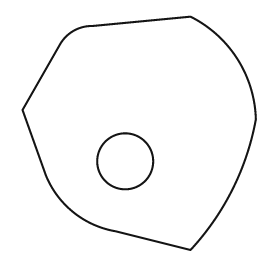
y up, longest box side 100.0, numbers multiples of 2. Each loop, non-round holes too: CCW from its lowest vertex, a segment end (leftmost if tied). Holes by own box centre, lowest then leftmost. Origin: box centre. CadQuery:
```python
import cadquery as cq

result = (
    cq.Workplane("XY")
    .moveTo(22.0, -50.0)
    .threePointArc((40.0, -24.0), (50.0, 6.0))
    .threePointArc((42.0, 32.0), (22.0, 50.0))
    .lineTo(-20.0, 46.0)
    .threePointArc((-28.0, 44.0), (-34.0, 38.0))
    .lineTo(-50.0, 10.0)
    .lineTo(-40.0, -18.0)
    .threePointArc((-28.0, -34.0), (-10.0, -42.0))
    .close()
    .moveTo(-6.0, -12.0)
    .circle(12.0)
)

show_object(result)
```